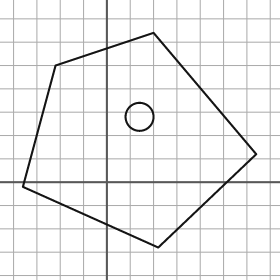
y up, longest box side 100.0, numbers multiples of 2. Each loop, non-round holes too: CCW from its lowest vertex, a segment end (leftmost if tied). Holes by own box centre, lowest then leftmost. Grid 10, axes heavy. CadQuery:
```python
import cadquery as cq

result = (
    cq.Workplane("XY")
    .moveTo(22.0, -28.0)
    .lineTo(64.0, 12.0)
    .lineTo(20.0, 64.0)
    .lineTo(-22.0, 50.0)
    .lineTo(-36.0, -2.0)
    .close()
    .moveTo(14.0, 28.0)
    .circle(6.0)
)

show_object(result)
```